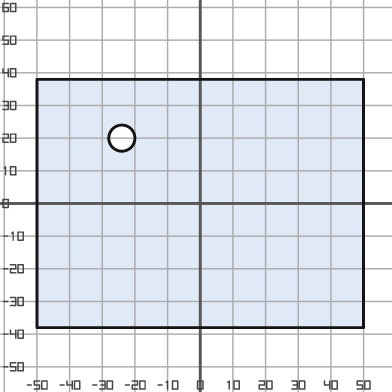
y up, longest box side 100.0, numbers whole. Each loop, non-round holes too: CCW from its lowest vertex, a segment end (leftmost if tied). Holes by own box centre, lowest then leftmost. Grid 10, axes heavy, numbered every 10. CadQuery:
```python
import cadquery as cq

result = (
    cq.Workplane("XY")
    .moveTo(-50.0, -38.0)
    .lineTo(50.0, -38.0)
    .lineTo(50.0, 38.0)
    .lineTo(-50.0, 38.0)
    .close()
    .moveTo(-24.0, 20.0)
    .circle(4.0)
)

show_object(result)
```